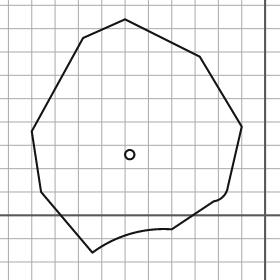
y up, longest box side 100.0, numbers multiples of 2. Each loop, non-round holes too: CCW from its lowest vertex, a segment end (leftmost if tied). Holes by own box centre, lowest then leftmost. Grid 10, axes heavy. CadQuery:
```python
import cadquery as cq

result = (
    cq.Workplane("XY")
    .moveTo(-74.0, -16.0)
    .threePointArc((-58.0, -8.0), (-40.0, -6.0))
    .lineTo(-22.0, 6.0)
    .threePointArc((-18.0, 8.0), (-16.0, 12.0))
    .lineTo(-10.0, 38.0)
    .lineTo(-28.0, 68.0)
    .lineTo(-60.0, 84.0)
    .lineTo(-78.0, 76.0)
    .lineTo(-100.0, 36.0)
    .lineTo(-96.0, 10.0)
    .close()
    .moveTo(-58.0, 26.0)
    .circle(2.0)
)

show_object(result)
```